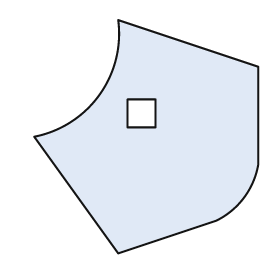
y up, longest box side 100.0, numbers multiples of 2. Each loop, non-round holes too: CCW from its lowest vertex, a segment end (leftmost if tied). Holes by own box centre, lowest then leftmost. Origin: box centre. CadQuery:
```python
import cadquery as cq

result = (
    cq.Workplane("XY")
    .moveTo(-12.0, -50.0)
    .lineTo(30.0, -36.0)
    .threePointArc((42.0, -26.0), (48.0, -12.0))
    .lineTo(48.0, 30.0)
    .lineTo(-12.0, 50.0)
    .threePointArc((-20.0, 18.0), (-48.0, 0.0))
    .close()
    .moveTo(-8.0, 4.0)
    .lineTo(4.0, 4.0)
    .lineTo(4.0, 16.0)
    .lineTo(-8.0, 16.0)
    .close()
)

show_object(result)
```